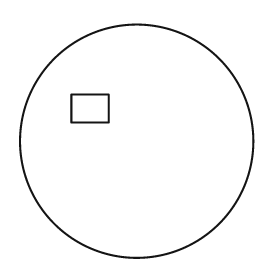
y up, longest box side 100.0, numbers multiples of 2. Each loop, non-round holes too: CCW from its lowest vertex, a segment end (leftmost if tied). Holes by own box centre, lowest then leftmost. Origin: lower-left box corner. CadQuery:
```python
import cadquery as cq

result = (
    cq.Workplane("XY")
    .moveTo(50.0, 50.0)
    .circle(50.0)
    .moveTo(22.0, 58.0)
    .lineTo(38.0, 58.0)
    .lineTo(38.0, 70.0)
    .lineTo(22.0, 70.0)
    .close()
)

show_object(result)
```